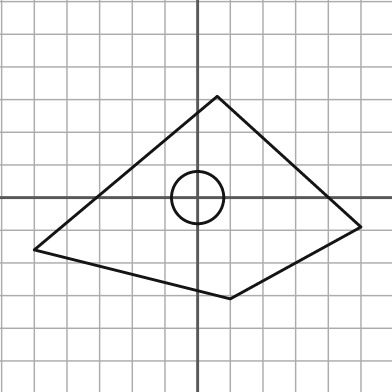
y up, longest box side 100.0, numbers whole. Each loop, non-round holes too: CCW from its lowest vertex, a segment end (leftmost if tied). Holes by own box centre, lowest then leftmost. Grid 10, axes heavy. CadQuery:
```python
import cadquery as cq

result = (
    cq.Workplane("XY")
    .moveTo(10.0, -31.0)
    .lineTo(50.0, -9.0)
    .lineTo(6.0, 31.0)
    .lineTo(-50.0, -16.0)
    .close()
    .moveTo(0.0, 0.0)
    .circle(8.0)
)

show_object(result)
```